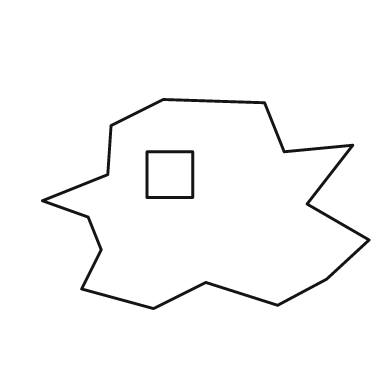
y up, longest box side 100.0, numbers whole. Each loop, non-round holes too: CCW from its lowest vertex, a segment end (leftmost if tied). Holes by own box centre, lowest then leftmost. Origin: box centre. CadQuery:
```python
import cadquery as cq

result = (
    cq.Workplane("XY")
    .moveTo(-16.0, -32.0)
    .lineTo(0.0, -24.0)
    .lineTo(22.0, -31.0)
    .lineTo(37.0, -23.0)
    .lineTo(50.0, -11.0)
    .lineTo(31.0, 0.0)
    .lineTo(45.0, 18.0)
    .lineTo(24.0, 16.0)
    .lineTo(18.0, 31.0)
    .lineTo(-13.0, 32.0)
    .lineTo(-29.0, 24.0)
    .lineTo(-30.0, 9.0)
    .lineTo(-50.0, 1.0)
    .lineTo(-36.0, -4.0)
    .lineTo(-32.0, -14.0)
    .lineTo(-38.0, -26.0)
    .close()
    .moveTo(-18.0, 2.0)
    .lineTo(-4.0, 2.0)
    .lineTo(-4.0, 16.0)
    .lineTo(-18.0, 16.0)
    .close()
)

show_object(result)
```